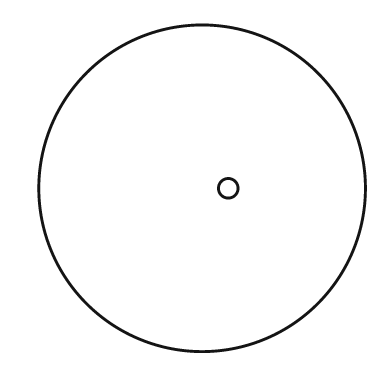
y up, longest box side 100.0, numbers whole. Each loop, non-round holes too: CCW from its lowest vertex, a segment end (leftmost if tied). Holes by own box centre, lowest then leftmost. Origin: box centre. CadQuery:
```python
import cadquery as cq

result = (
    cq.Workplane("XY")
    .moveTo(0.0, 0.0)
    .circle(50.0)
    .moveTo(8.0, 0.0)
    .circle(3.0)
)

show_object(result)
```